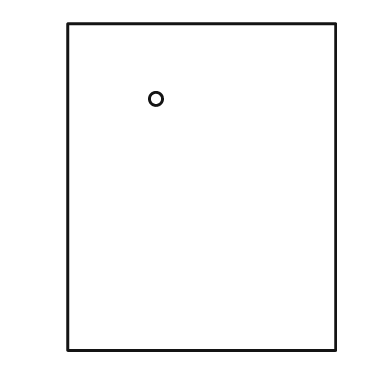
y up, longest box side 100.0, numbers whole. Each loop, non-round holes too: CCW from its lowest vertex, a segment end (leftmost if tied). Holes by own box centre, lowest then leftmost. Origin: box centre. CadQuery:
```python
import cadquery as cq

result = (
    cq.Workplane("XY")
    .moveTo(-41.0, -50.0)
    .lineTo(41.0, -50.0)
    .lineTo(41.0, 50.0)
    .lineTo(-41.0, 50.0)
    .close()
    .moveTo(-14.0, 27.0)
    .circle(2.0)
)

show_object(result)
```